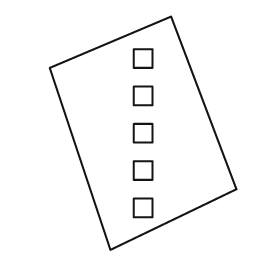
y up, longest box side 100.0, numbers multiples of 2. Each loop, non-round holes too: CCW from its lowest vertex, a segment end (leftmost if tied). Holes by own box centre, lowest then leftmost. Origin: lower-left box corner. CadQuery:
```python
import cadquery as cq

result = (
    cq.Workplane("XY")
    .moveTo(26.0, 0.0)
    .lineTo(80.0, 26.0)
    .lineTo(52.0, 100.0)
    .lineTo(0.0, 78.0)
    .close()
    .moveTo(36.0, 14.0)
    .lineTo(44.0, 14.0)
    .lineTo(44.0, 22.0)
    .lineTo(36.0, 22.0)
    .close()
    .moveTo(36.0, 30.0)
    .lineTo(44.0, 30.0)
    .lineTo(44.0, 38.0)
    .lineTo(36.0, 38.0)
    .close()
    .moveTo(36.0, 46.0)
    .lineTo(44.0, 46.0)
    .lineTo(44.0, 54.0)
    .lineTo(36.0, 54.0)
    .close()
    .moveTo(36.0, 62.0)
    .lineTo(44.0, 62.0)
    .lineTo(44.0, 70.0)
    .lineTo(36.0, 70.0)
    .close()
    .moveTo(36.0, 78.0)
    .lineTo(44.0, 78.0)
    .lineTo(44.0, 86.0)
    .lineTo(36.0, 86.0)
    .close()
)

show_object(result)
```